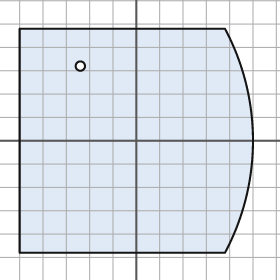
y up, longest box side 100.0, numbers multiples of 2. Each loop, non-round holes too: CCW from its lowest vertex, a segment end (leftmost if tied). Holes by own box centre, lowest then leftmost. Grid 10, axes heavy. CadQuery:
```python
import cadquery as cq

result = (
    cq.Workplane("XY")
    .moveTo(-50.0, -48.0)
    .lineTo(38.0, -48.0)
    .threePointArc((50.0, 0.0), (38.0, 48.0))
    .lineTo(-50.0, 48.0)
    .close()
    .moveTo(-24.0, 32.0)
    .circle(2.0)
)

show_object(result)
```